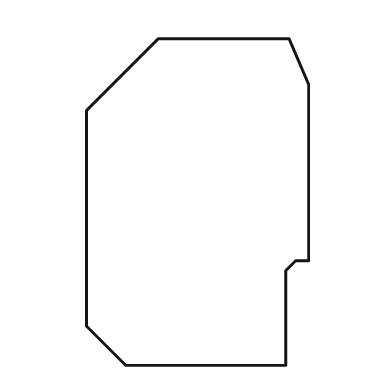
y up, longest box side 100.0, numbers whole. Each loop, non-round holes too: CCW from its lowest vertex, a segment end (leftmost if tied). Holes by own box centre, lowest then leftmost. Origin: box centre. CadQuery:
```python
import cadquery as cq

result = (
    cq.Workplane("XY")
    .moveTo(-22.0, -50.0)
    .lineTo(27.0, -50.0)
    .lineTo(27.0, -21.0)
    .lineTo(30.0, -18.0)
    .lineTo(34.0, -18.0)
    .lineTo(34.0, 36.0)
    .lineTo(28.0, 50.0)
    .lineTo(-12.0, 50.0)
    .lineTo(-34.0, 28.0)
    .lineTo(-34.0, -38.0)
    .close()
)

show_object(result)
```